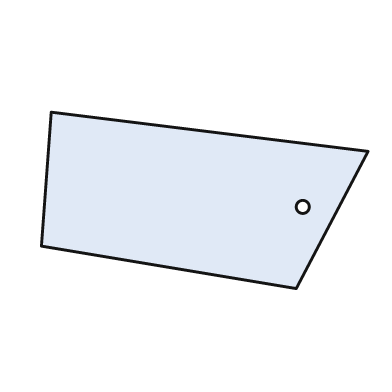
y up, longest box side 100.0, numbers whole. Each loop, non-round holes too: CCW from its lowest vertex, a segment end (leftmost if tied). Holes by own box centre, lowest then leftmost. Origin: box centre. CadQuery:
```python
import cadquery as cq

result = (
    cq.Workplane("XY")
    .moveTo(28.0, -27.0)
    .lineTo(50.0, 15.0)
    .lineTo(-47.0, 27.0)
    .lineTo(-50.0, -14.0)
    .close()
    .moveTo(30.0, -2.0)
    .circle(2.0)
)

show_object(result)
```